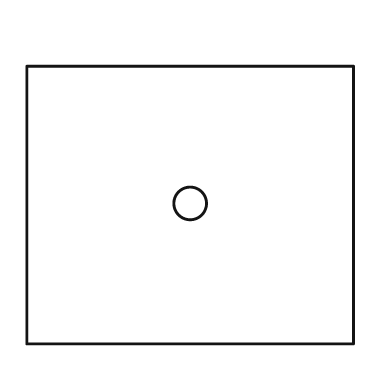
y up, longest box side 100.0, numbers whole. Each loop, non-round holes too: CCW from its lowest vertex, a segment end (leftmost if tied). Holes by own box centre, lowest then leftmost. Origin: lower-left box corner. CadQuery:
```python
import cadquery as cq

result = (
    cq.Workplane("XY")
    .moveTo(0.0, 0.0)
    .lineTo(100.0, 0.0)
    .lineTo(100.0, 85.0)
    .lineTo(0.0, 85.0)
    .close()
    .moveTo(50.0, 43.0)
    .circle(5.0)
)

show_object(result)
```